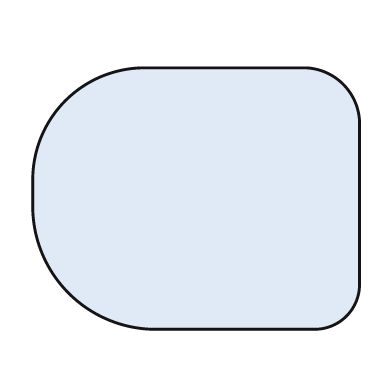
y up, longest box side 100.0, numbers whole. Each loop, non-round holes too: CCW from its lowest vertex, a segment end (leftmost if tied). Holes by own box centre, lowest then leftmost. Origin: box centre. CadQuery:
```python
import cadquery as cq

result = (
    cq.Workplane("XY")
    .moveTo(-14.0, -40.0)
    .lineTo(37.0, -40.0)
    .threePointArc((46.0, -36.0), (50.0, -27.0))
    .lineTo(50.0, 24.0)
    .threePointArc((45.0, 35.0), (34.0, 40.0))
    .lineTo(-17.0, 40.0)
    .threePointArc((-40.0, 30.0), (-50.0, 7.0))
    .lineTo(-50.0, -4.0)
    .threePointArc((-39.0, -29.0), (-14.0, -40.0))
    .close()
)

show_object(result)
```